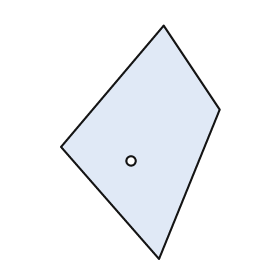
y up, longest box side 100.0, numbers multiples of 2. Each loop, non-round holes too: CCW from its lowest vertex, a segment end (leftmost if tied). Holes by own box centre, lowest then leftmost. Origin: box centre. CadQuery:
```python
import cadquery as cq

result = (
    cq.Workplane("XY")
    .moveTo(8.0, -50.0)
    .lineTo(34.0, 14.0)
    .lineTo(10.0, 50.0)
    .lineTo(-34.0, -2.0)
    .close()
    .moveTo(-4.0, -8.0)
    .circle(2.0)
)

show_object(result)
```